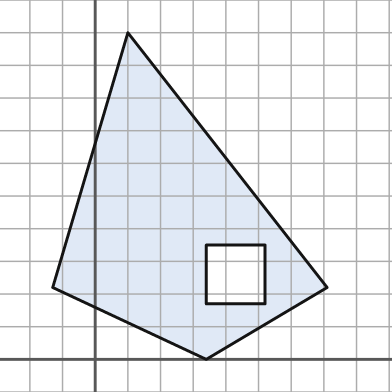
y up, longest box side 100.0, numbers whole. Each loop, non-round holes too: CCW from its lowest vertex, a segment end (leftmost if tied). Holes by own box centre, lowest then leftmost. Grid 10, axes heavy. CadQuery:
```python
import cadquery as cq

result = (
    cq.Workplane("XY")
    .moveTo(34.0, 0.0)
    .lineTo(71.0, 22.0)
    .lineTo(10.0, 100.0)
    .lineTo(-13.0, 22.0)
    .close()
    .moveTo(34.0, 17.0)
    .lineTo(52.0, 17.0)
    .lineTo(52.0, 35.0)
    .lineTo(34.0, 35.0)
    .close()
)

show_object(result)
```